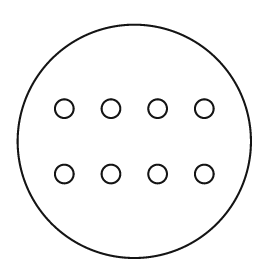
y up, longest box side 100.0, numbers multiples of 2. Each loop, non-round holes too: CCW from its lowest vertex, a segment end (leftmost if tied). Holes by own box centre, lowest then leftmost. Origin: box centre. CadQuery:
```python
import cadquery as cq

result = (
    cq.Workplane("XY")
    .moveTo(0.0, 0.0)
    .circle(50.0)
    .moveTo(-30.0, -14.0)
    .circle(4.0)
    .moveTo(-10.0, -14.0)
    .circle(4.0)
    .moveTo(10.0, -14.0)
    .circle(4.0)
    .moveTo(30.0, -14.0)
    .circle(4.0)
    .moveTo(-30.0, 14.0)
    .circle(4.0)
    .moveTo(-10.0, 14.0)
    .circle(4.0)
    .moveTo(10.0, 14.0)
    .circle(4.0)
    .moveTo(30.0, 14.0)
    .circle(4.0)
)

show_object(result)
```